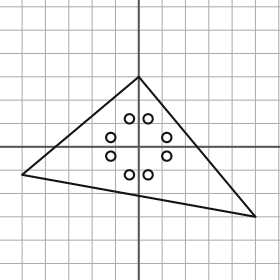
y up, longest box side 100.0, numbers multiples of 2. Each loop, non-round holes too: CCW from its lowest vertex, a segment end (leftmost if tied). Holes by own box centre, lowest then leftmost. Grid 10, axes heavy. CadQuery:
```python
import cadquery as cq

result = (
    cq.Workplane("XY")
    .moveTo(50.0, -30.0)
    .lineTo(0.0, 30.0)
    .lineTo(-50.0, -12.0)
    .close()
    .moveTo(-4.0, -12.0)
    .circle(2.0)
    .moveTo(4.0, -12.0)
    .circle(2.0)
    .moveTo(-12.0, -4.0)
    .circle(2.0)
    .moveTo(12.0, -4.0)
    .circle(2.0)
    .moveTo(-12.0, 4.0)
    .circle(2.0)
    .moveTo(12.0, 4.0)
    .circle(2.0)
    .moveTo(-4.0, 12.0)
    .circle(2.0)
    .moveTo(4.0, 12.0)
    .circle(2.0)
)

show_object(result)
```